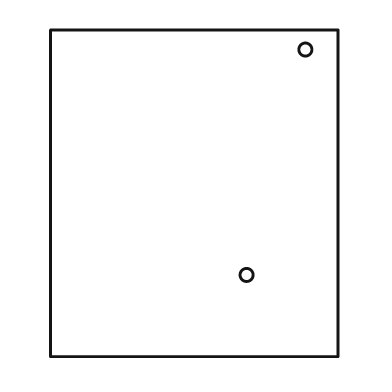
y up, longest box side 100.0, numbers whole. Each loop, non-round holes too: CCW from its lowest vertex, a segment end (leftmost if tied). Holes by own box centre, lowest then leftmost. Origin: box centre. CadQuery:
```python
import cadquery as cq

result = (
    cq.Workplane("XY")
    .moveTo(-44.0, -50.0)
    .lineTo(44.0, -50.0)
    .lineTo(44.0, 50.0)
    .lineTo(-44.0, 50.0)
    .close()
    .moveTo(16.0, -25.0)
    .circle(2.0)
    .moveTo(34.0, 44.0)
    .circle(2.0)
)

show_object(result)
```